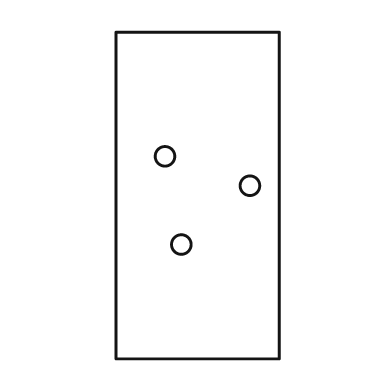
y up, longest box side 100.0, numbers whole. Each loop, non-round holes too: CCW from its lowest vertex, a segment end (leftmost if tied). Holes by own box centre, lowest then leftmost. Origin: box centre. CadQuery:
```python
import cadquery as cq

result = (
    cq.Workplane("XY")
    .moveTo(-25.0, -50.0)
    .lineTo(25.0, -50.0)
    .lineTo(25.0, 50.0)
    .lineTo(-25.0, 50.0)
    .close()
    .moveTo(-5.0, -15.0)
    .circle(3.0)
    .moveTo(16.0, 3.0)
    .circle(3.0)
    .moveTo(-10.0, 12.0)
    .circle(3.0)
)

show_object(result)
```